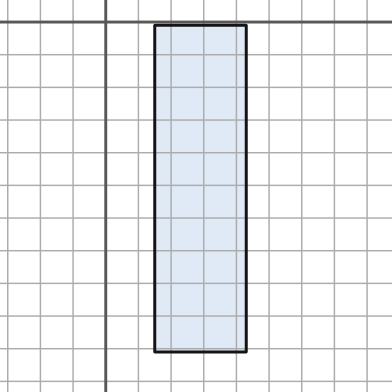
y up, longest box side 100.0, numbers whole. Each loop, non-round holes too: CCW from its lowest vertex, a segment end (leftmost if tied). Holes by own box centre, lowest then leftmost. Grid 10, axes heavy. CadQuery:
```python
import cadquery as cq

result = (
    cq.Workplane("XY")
    .moveTo(15.0, -101.0)
    .lineTo(43.0, -101.0)
    .lineTo(43.0, -1.0)
    .lineTo(15.0, -1.0)
    .close()
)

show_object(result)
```